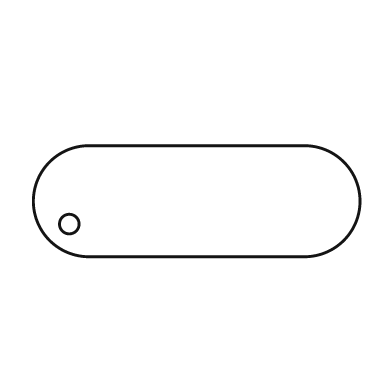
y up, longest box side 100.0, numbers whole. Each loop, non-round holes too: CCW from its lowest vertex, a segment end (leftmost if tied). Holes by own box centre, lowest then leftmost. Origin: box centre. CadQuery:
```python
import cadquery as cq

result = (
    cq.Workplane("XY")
    .moveTo(-33.0, -17.0)
    .lineTo(33.0, -17.0)
    .threePointArc((50.0, 0.0), (33.0, 17.0))
    .lineTo(-33.0, 17.0)
    .threePointArc((-50.0, 0.0), (-33.0, -17.0))
    .close()
    .moveTo(-39.0, -7.0)
    .circle(3.0)
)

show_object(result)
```